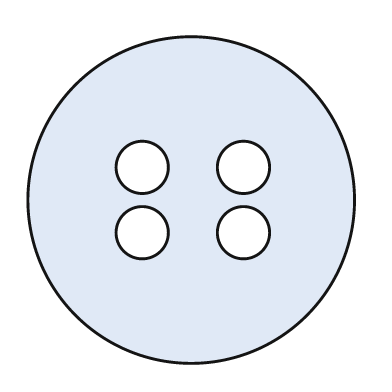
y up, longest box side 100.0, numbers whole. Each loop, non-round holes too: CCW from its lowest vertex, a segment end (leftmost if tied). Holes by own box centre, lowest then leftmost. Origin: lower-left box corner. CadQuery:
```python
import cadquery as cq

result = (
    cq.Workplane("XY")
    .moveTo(50.0, 50.0)
    .circle(50.0)
    .moveTo(35.0, 40.0)
    .circle(8.0)
    .moveTo(66.0, 40.0)
    .circle(8.0)
    .moveTo(35.0, 60.0)
    .circle(8.0)
    .moveTo(66.0, 60.0)
    .circle(8.0)
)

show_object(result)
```